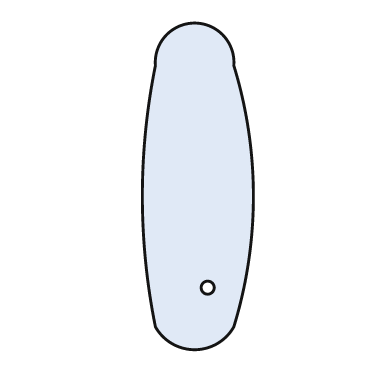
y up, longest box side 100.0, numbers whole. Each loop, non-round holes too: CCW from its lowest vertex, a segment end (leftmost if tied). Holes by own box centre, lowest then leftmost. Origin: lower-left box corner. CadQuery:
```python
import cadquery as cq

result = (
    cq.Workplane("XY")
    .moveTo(4.0, 7.0)
    .threePointArc((16.0, 0.0), (28.0, 7.0))
    .threePointArc((34.0, 47.0), (28.0, 87.0))
    .threePointArc((16.0, 100.0), (4.0, 87.0))
    .threePointArc((0.0, 47.0), (4.0, 7.0))
    .close()
    .moveTo(20.0, 19.0)
    .circle(2.0)
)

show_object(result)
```